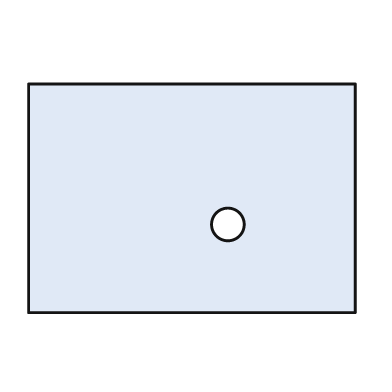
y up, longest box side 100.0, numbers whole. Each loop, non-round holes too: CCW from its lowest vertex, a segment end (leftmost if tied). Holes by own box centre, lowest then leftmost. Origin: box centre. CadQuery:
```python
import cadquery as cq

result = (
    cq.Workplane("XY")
    .moveTo(-50.0, -35.0)
    .lineTo(50.0, -35.0)
    .lineTo(50.0, 35.0)
    .lineTo(-50.0, 35.0)
    .close()
    .moveTo(11.0, -8.0)
    .circle(5.0)
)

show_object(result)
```